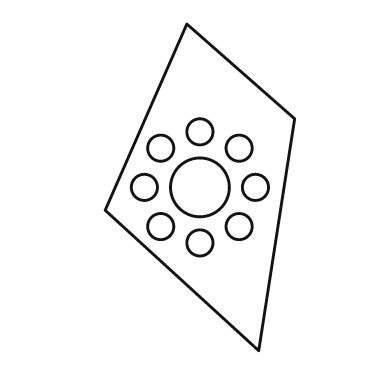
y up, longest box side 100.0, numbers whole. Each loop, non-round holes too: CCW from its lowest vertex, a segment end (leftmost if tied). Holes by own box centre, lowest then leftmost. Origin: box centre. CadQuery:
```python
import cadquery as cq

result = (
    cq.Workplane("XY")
    .moveTo(18.0, -50.0)
    .lineTo(29.0, 21.0)
    .lineTo(-4.0, 50.0)
    .lineTo(-29.0, -7.0)
    .close()
    .moveTo(0.0, -17.0)
    .circle(4.0)
    .moveTo(-12.0, -12.0)
    .circle(4.0)
    .moveTo(12.0, -12.0)
    .circle(4.0)
    .moveTo(-17.0, 0.0)
    .circle(4.0)
    .moveTo(0.0, 0.0)
    .circle(9.0)
    .moveTo(17.0, 0.0)
    .circle(4.0)
    .moveTo(-12.0, 12.0)
    .circle(4.0)
    .moveTo(12.0, 12.0)
    .circle(4.0)
    .moveTo(0.0, 17.0)
    .circle(4.0)
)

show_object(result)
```